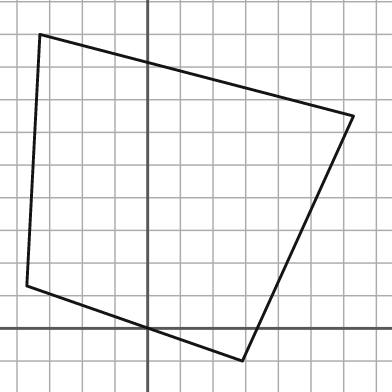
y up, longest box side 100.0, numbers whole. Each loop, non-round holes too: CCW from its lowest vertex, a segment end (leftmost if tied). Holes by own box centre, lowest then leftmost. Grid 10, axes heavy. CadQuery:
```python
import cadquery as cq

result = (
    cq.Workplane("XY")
    .moveTo(29.0, -10.0)
    .lineTo(63.0, 65.0)
    .lineTo(-33.0, 90.0)
    .lineTo(-37.0, 13.0)
    .close()
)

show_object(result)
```